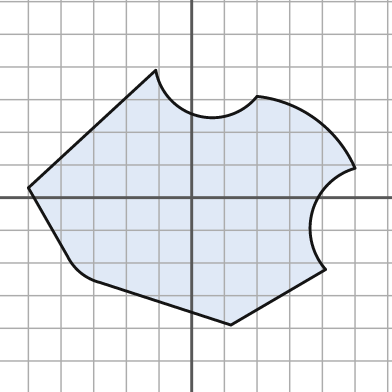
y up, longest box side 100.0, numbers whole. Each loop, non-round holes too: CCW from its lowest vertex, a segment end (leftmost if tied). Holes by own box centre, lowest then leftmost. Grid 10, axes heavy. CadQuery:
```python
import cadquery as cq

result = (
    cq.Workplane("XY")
    .moveTo(12.0, -39.0)
    .lineTo(41.0, -22.0)
    .threePointArc((37.0, -4.0), (50.0, 9.0))
    .threePointArc((38.0, 24.0), (20.0, 31.0))
    .threePointArc((2.0, 25.0), (-11.0, 39.0))
    .lineTo(-50.0, 3.0)
    .lineTo(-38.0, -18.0)
    .threePointArc((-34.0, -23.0), (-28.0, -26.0))
    .close()
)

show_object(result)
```